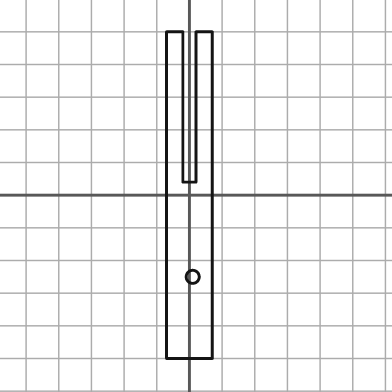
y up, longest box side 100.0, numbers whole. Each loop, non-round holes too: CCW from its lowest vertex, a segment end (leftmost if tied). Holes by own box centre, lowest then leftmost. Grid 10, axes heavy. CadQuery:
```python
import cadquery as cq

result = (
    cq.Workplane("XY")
    .moveTo(-7.0, -50.0)
    .lineTo(7.0, -50.0)
    .lineTo(7.0, 50.0)
    .lineTo(2.0, 50.0)
    .lineTo(2.0, 4.0)
    .lineTo(-2.0, 4.0)
    .lineTo(-2.0, 50.0)
    .lineTo(-7.0, 50.0)
    .close()
    .moveTo(1.0, -25.0)
    .circle(2.0)
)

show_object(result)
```